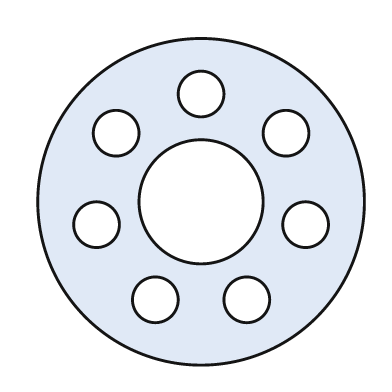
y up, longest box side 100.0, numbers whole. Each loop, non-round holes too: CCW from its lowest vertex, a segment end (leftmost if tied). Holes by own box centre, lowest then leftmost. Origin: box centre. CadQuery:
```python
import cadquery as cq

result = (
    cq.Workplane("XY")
    .moveTo(0.0, 0.0)
    .circle(50.0)
    .moveTo(-14.0, -30.0)
    .circle(7.0)
    .moveTo(14.0, -30.0)
    .circle(7.0)
    .moveTo(-32.0, -7.0)
    .circle(7.0)
    .moveTo(32.0, -7.0)
    .circle(7.0)
    .moveTo(0.0, 0.0)
    .circle(19.0)
    .moveTo(-26.0, 21.0)
    .circle(7.0)
    .moveTo(26.0, 21.0)
    .circle(7.0)
    .moveTo(0.0, 33.0)
    .circle(7.0)
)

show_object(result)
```